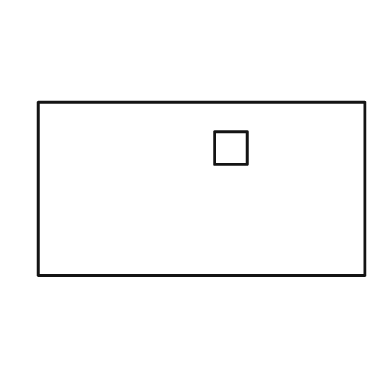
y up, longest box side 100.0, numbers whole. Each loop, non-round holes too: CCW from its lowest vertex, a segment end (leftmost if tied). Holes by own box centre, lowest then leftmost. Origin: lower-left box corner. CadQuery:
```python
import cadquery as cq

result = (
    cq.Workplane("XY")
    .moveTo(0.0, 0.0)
    .lineTo(100.0, 0.0)
    .lineTo(100.0, 53.0)
    .lineTo(0.0, 53.0)
    .close()
    .moveTo(54.0, 34.0)
    .lineTo(64.0, 34.0)
    .lineTo(64.0, 44.0)
    .lineTo(54.0, 44.0)
    .close()
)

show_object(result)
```